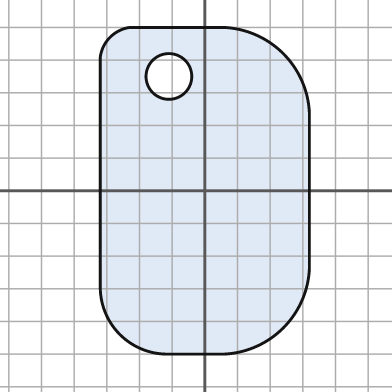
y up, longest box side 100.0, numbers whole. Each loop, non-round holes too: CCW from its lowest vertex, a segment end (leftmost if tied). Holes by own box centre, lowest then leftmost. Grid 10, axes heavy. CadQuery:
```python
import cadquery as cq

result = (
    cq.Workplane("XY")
    .moveTo(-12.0, -50.0)
    .lineTo(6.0, -50.0)
    .threePointArc((24.0, -42.0), (32.0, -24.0))
    .lineTo(32.0, 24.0)
    .threePointArc((24.0, 42.0), (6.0, 50.0))
    .lineTo(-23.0, 50.0)
    .threePointArc((-29.0, 47.0), (-32.0, 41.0))
    .lineTo(-32.0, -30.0)
    .threePointArc((-26.0, -44.0), (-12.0, -50.0))
    .close()
    .moveTo(-11.0, 35.0)
    .circle(7.0)
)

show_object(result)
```